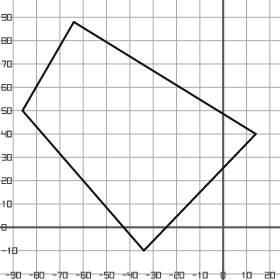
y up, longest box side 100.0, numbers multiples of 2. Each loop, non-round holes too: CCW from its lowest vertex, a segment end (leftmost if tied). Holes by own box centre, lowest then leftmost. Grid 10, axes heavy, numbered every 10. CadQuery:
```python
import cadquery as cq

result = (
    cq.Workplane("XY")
    .moveTo(-34.0, -10.0)
    .lineTo(14.0, 40.0)
    .lineTo(-64.0, 88.0)
    .lineTo(-86.0, 50.0)
    .close()
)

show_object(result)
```